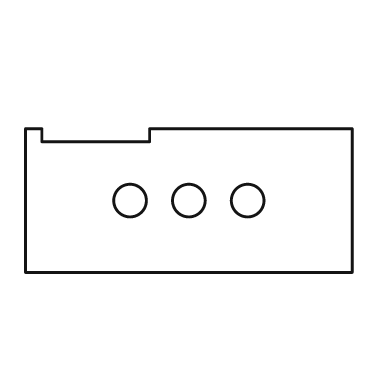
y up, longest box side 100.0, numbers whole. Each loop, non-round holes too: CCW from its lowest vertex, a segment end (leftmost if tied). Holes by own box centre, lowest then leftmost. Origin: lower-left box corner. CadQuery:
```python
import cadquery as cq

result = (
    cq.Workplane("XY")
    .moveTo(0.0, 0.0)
    .lineTo(100.0, 0.0)
    .lineTo(100.0, 44.0)
    .lineTo(38.0, 44.0)
    .lineTo(38.0, 40.0)
    .lineTo(5.0, 40.0)
    .lineTo(5.0, 44.0)
    .lineTo(0.0, 44.0)
    .close()
    .moveTo(32.0, 22.0)
    .circle(5.0)
    .moveTo(50.0, 22.0)
    .circle(5.0)
    .moveTo(68.0, 22.0)
    .circle(5.0)
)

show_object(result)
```